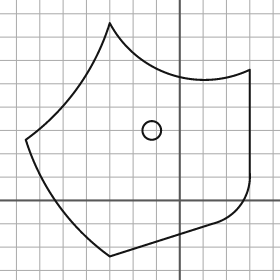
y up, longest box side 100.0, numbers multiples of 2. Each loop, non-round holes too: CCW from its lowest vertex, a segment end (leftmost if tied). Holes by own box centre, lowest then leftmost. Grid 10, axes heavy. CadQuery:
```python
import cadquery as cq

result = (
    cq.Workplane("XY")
    .moveTo(-30.0, -24.0)
    .lineTo(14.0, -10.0)
    .threePointArc((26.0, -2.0), (30.0, 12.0))
    .lineTo(30.0, 56.0)
    .threePointArc((-4.0, 54.0), (-30.0, 76.0))
    .threePointArc((-44.0, 48.0), (-66.0, 26.0))
    .threePointArc((-52.0, -2.0), (-30.0, -24.0))
    .close()
    .moveTo(-12.0, 30.0)
    .circle(4.0)
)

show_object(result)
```